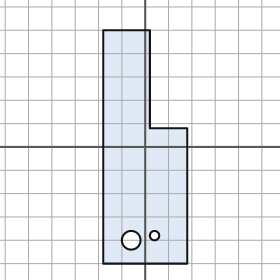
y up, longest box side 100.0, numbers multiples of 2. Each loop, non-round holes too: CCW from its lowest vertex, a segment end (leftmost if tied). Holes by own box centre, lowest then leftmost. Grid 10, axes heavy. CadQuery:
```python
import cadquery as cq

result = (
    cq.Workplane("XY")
    .moveTo(-18.0, -50.0)
    .lineTo(18.0, -50.0)
    .lineTo(18.0, 8.0)
    .lineTo(2.0, 8.0)
    .lineTo(2.0, 50.0)
    .lineTo(-18.0, 50.0)
    .close()
    .moveTo(-6.0, -40.0)
    .circle(4.0)
    .moveTo(4.0, -38.0)
    .circle(2.0)
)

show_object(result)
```